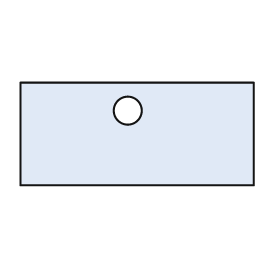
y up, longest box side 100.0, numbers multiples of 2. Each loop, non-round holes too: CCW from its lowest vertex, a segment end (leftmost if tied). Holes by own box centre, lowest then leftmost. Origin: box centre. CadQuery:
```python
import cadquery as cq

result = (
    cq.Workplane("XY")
    .moveTo(-50.0, -22.0)
    .lineTo(50.0, -22.0)
    .lineTo(50.0, 22.0)
    .lineTo(-50.0, 22.0)
    .close()
    .moveTo(-4.0, 10.0)
    .circle(6.0)
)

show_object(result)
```